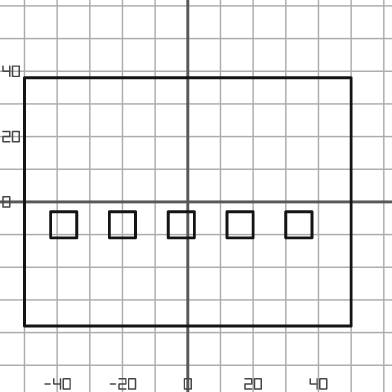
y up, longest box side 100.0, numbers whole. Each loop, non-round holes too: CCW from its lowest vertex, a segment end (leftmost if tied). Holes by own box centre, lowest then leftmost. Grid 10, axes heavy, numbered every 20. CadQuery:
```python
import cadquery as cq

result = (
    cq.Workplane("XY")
    .moveTo(-50.0, -38.0)
    .lineTo(50.0, -38.0)
    .lineTo(50.0, 38.0)
    .lineTo(-50.0, 38.0)
    .close()
    .moveTo(-42.0, -11.0)
    .lineTo(-34.0, -11.0)
    .lineTo(-34.0, -3.0)
    .lineTo(-42.0, -3.0)
    .close()
    .moveTo(-24.0, -11.0)
    .lineTo(-16.0, -11.0)
    .lineTo(-16.0, -3.0)
    .lineTo(-24.0, -3.0)
    .close()
    .moveTo(-6.0, -11.0)
    .lineTo(2.0, -11.0)
    .lineTo(2.0, -3.0)
    .lineTo(-6.0, -3.0)
    .close()
    .moveTo(12.0, -11.0)
    .lineTo(20.0, -11.0)
    .lineTo(20.0, -3.0)
    .lineTo(12.0, -3.0)
    .close()
    .moveTo(30.0, -11.0)
    .lineTo(38.0, -11.0)
    .lineTo(38.0, -3.0)
    .lineTo(30.0, -3.0)
    .close()
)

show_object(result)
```